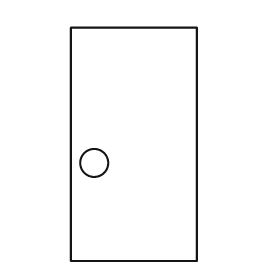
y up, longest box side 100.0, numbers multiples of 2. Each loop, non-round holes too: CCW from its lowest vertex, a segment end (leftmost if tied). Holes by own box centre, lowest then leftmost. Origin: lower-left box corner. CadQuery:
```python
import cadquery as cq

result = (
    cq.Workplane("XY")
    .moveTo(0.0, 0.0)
    .lineTo(54.0, 0.0)
    .lineTo(54.0, 100.0)
    .lineTo(0.0, 100.0)
    .close()
    .moveTo(10.0, 42.0)
    .circle(6.0)
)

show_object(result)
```